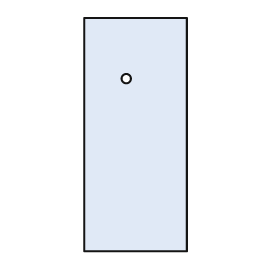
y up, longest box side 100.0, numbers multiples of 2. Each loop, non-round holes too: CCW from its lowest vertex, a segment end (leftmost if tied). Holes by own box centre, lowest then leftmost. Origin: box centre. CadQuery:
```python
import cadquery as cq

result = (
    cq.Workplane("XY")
    .moveTo(-22.0, -50.0)
    .lineTo(22.0, -50.0)
    .lineTo(22.0, 50.0)
    .lineTo(-22.0, 50.0)
    .close()
    .moveTo(-4.0, 24.0)
    .circle(2.0)
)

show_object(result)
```